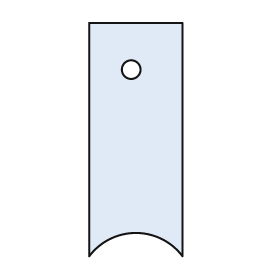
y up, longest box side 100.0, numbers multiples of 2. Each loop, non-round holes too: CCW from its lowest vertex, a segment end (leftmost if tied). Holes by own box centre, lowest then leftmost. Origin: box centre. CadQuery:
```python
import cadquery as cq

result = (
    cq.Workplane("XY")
    .moveTo(-20.0, -50.0)
    .threePointArc((0.0, -40.0), (20.0, -50.0))
    .lineTo(20.0, 50.0)
    .lineTo(-20.0, 50.0)
    .close()
    .moveTo(-2.0, 30.0)
    .circle(4.0)
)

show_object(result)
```